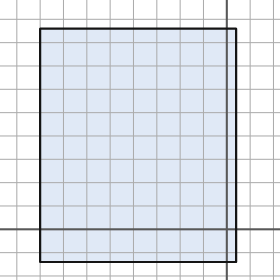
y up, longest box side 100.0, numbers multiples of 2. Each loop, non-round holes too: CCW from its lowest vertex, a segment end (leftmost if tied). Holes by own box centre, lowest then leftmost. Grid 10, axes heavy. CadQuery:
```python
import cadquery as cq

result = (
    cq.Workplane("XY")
    .moveTo(-80.0, -14.0)
    .lineTo(4.0, -14.0)
    .lineTo(4.0, 86.0)
    .lineTo(-80.0, 86.0)
    .close()
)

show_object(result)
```